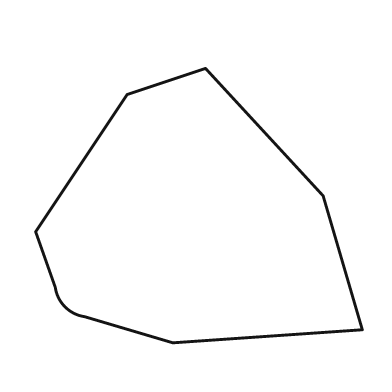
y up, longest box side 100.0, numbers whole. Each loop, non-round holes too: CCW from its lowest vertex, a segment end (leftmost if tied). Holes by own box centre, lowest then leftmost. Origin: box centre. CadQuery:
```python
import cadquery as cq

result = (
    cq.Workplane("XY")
    .moveTo(-8.0, -42.0)
    .lineTo(50.0, -38.0)
    .lineTo(38.0, 3.0)
    .lineTo(2.0, 42.0)
    .lineTo(-22.0, 34.0)
    .lineTo(-50.0, -8.0)
    .lineTo(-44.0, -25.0)
    .threePointArc((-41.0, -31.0), (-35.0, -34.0))
    .close()
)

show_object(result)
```